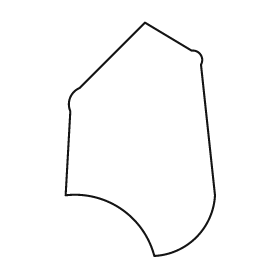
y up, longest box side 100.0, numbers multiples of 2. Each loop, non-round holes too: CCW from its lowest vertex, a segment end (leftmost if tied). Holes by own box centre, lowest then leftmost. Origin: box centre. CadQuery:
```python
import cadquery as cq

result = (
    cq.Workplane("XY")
    .moveTo(6.0, -50.0)
    .threePointArc((24.0, -42.0), (32.0, -24.0))
    .lineTo(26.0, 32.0)
    .threePointArc((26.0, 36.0), (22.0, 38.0))
    .lineTo(2.0, 50.0)
    .lineTo(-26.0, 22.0)
    .threePointArc((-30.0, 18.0), (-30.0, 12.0))
    .lineTo(-32.0, -24.0)
    .threePointArc((-8.0, -30.0), (6.0, -50.0))
    .close()
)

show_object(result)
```